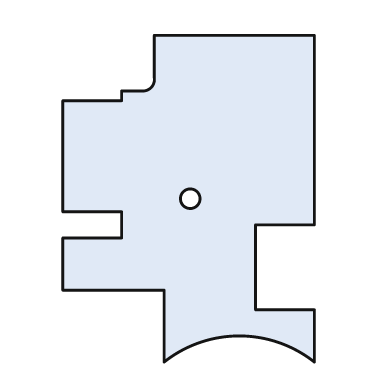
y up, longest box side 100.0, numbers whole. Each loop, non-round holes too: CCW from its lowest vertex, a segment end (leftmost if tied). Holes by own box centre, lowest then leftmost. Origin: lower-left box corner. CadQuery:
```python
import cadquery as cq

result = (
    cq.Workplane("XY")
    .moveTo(31.0, 0.0)
    .threePointArc((54.0, 8.0), (77.0, 0.0))
    .lineTo(77.0, 16.0)
    .lineTo(59.0, 16.0)
    .lineTo(59.0, 42.0)
    .lineTo(77.0, 42.0)
    .lineTo(77.0, 100.0)
    .lineTo(28.0, 100.0)
    .lineTo(28.0, 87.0)
    .threePointArc((27.0, 84.0), (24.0, 83.0))
    .lineTo(18.0, 83.0)
    .lineTo(18.0, 80.0)
    .lineTo(0.0, 80.0)
    .lineTo(0.0, 46.0)
    .lineTo(18.0, 46.0)
    .lineTo(18.0, 38.0)
    .lineTo(0.0, 38.0)
    .lineTo(0.0, 22.0)
    .lineTo(31.0, 22.0)
    .close()
    .moveTo(39.0, 50.0)
    .circle(3.0)
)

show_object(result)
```